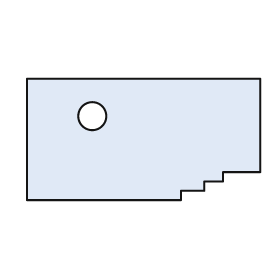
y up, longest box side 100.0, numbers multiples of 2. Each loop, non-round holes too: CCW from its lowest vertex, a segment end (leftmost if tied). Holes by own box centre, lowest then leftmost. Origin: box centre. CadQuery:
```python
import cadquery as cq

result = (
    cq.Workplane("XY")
    .moveTo(-50.0, -26.0)
    .lineTo(16.0, -26.0)
    .lineTo(16.0, -22.0)
    .lineTo(26.0, -22.0)
    .lineTo(26.0, -18.0)
    .lineTo(34.0, -18.0)
    .lineTo(34.0, -14.0)
    .lineTo(50.0, -14.0)
    .lineTo(50.0, 26.0)
    .lineTo(-50.0, 26.0)
    .close()
    .moveTo(-22.0, 10.0)
    .circle(6.0)
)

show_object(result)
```